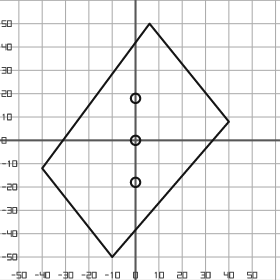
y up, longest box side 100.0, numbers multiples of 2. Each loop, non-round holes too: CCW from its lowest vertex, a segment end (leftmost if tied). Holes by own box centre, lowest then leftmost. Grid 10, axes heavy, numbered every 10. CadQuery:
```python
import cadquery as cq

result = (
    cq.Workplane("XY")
    .moveTo(-10.0, -50.0)
    .lineTo(40.0, 8.0)
    .lineTo(6.0, 50.0)
    .lineTo(-40.0, -12.0)
    .close()
    .moveTo(0.0, -18.0)
    .circle(2.0)
    .moveTo(0.0, 0.0)
    .circle(2.0)
    .moveTo(0.0, 18.0)
    .circle(2.0)
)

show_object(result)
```